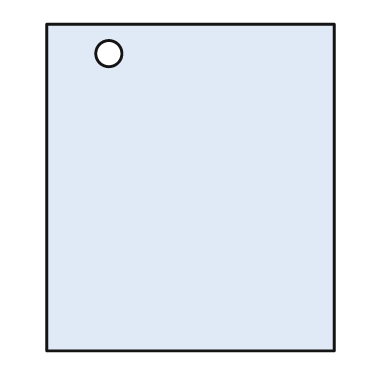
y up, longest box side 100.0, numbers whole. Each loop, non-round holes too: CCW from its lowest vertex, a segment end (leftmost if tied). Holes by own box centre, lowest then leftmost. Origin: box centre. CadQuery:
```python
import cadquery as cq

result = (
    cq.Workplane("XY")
    .moveTo(-44.0, -50.0)
    .lineTo(44.0, -50.0)
    .lineTo(44.0, 50.0)
    .lineTo(-44.0, 50.0)
    .close()
    .moveTo(-25.0, 41.0)
    .circle(4.0)
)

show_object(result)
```